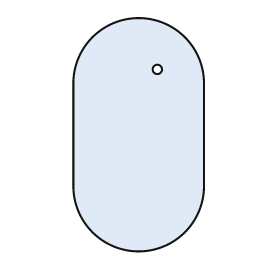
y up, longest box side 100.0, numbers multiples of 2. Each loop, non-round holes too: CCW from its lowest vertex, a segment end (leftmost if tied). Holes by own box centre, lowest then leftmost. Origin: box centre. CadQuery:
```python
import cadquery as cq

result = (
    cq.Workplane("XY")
    .moveTo(-28.0, -22.0)
    .threePointArc((0.0, -50.0), (28.0, -22.0))
    .lineTo(28.0, 22.0)
    .threePointArc((0.0, 50.0), (-28.0, 22.0))
    .close()
    .moveTo(8.0, 28.0)
    .circle(2.0)
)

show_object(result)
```